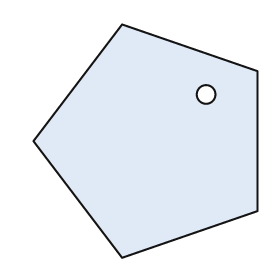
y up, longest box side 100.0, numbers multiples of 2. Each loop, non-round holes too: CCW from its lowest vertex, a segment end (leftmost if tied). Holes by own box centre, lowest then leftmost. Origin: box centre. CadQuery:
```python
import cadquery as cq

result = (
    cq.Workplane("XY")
    .moveTo(-10.0, -50.0)
    .lineTo(48.0, -30.0)
    .lineTo(48.0, 30.0)
    .lineTo(-10.0, 50.0)
    .lineTo(-48.0, 0.0)
    .close()
    .moveTo(26.0, 20.0)
    .circle(4.0)
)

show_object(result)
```